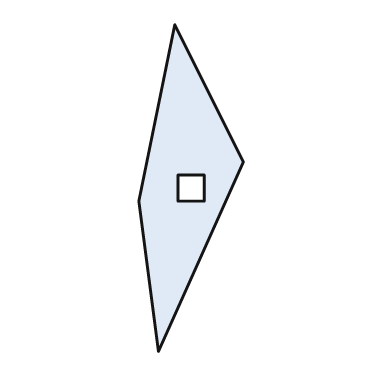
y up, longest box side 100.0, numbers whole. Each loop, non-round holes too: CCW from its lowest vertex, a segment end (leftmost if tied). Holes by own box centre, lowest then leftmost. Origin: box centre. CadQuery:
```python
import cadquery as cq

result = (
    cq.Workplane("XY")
    .moveTo(-10.0, -50.0)
    .lineTo(16.0, 8.0)
    .lineTo(-5.0, 50.0)
    .lineTo(-16.0, -4.0)
    .close()
    .moveTo(-4.0, -4.0)
    .lineTo(4.0, -4.0)
    .lineTo(4.0, 4.0)
    .lineTo(-4.0, 4.0)
    .close()
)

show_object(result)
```